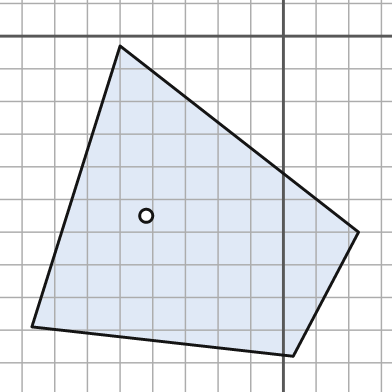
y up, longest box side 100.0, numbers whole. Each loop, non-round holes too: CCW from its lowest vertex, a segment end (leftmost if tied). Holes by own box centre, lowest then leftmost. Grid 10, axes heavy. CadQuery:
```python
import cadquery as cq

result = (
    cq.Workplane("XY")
    .moveTo(3.0, -98.0)
    .lineTo(23.0, -60.0)
    .lineTo(-50.0, -3.0)
    .lineTo(-77.0, -89.0)
    .close()
    .moveTo(-42.0, -55.0)
    .circle(2.0)
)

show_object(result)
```